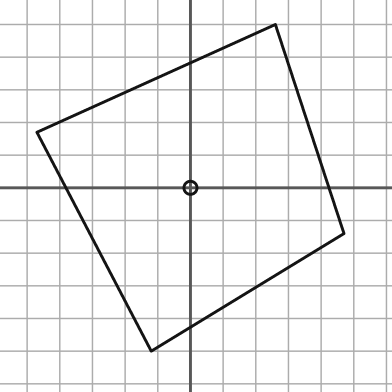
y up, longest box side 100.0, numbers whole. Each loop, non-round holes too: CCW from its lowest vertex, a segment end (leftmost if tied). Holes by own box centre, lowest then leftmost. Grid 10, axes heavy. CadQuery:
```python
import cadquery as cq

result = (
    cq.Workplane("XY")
    .moveTo(-12.0, -50.0)
    .lineTo(47.0, -14.0)
    .lineTo(26.0, 50.0)
    .lineTo(-47.0, 17.0)
    .close()
    .moveTo(0.0, 0.0)
    .circle(2.0)
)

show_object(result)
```